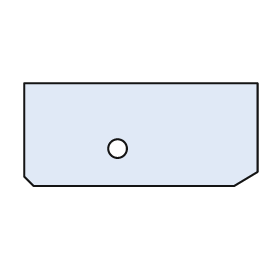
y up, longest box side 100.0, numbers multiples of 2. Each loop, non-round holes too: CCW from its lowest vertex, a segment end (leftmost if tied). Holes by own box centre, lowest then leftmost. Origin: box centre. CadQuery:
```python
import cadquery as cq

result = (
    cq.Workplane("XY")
    .moveTo(-46.0, -22.0)
    .lineTo(40.0, -22.0)
    .lineTo(50.0, -16.0)
    .lineTo(50.0, 22.0)
    .lineTo(-50.0, 22.0)
    .lineTo(-50.0, -18.0)
    .close()
    .moveTo(-10.0, -6.0)
    .circle(4.0)
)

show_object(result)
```